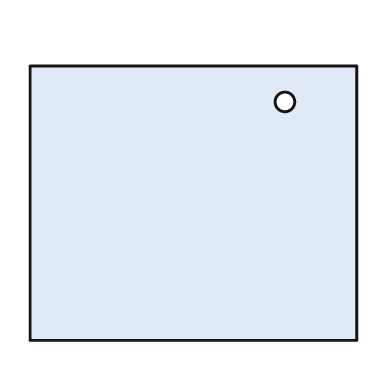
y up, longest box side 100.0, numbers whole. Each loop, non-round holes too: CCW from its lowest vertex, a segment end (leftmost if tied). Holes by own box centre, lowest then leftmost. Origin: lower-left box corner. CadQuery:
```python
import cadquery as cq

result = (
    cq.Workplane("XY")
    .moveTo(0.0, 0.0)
    .lineTo(100.0, 0.0)
    .lineTo(100.0, 84.0)
    .lineTo(0.0, 84.0)
    .close()
    .moveTo(78.0, 73.0)
    .circle(3.0)
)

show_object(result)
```